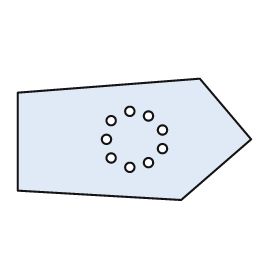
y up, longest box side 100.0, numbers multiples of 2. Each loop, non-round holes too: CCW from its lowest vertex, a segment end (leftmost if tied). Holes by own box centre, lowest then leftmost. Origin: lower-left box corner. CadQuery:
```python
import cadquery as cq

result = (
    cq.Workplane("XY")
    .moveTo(70.0, 0.0)
    .lineTo(100.0, 26.0)
    .lineTo(78.0, 52.0)
    .lineTo(0.0, 46.0)
    .lineTo(0.0, 4.0)
    .close()
    .moveTo(48.0, 14.0)
    .circle(2.0)
    .moveTo(56.0, 16.0)
    .circle(2.0)
    .moveTo(40.0, 18.0)
    .circle(2.0)
    .moveTo(62.0, 22.0)
    .circle(2.0)
    .moveTo(38.0, 26.0)
    .circle(2.0)
    .moveTo(62.0, 30.0)
    .circle(2.0)
    .moveTo(40.0, 34.0)
    .circle(2.0)
    .moveTo(56.0, 36.0)
    .circle(2.0)
    .moveTo(48.0, 38.0)
    .circle(2.0)
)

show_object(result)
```